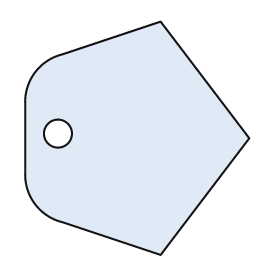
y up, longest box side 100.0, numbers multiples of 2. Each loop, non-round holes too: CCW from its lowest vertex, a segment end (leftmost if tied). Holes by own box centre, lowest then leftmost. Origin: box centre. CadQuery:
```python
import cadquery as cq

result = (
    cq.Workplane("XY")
    .moveTo(10.0, -50.0)
    .lineTo(48.0, 0.0)
    .lineTo(10.0, 50.0)
    .lineTo(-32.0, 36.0)
    .threePointArc((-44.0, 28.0), (-48.0, 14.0))
    .lineTo(-48.0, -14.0)
    .threePointArc((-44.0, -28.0), (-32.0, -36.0))
    .close()
    .moveTo(-34.0, 2.0)
    .circle(6.0)
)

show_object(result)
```